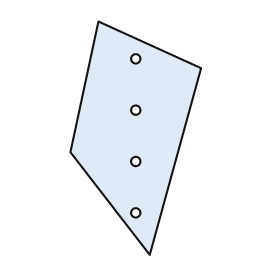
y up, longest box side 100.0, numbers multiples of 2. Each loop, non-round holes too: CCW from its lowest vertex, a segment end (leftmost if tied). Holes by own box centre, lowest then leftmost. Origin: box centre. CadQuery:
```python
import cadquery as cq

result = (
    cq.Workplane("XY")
    .moveTo(6.0, -50.0)
    .lineTo(28.0, 30.0)
    .lineTo(-16.0, 50.0)
    .lineTo(-28.0, -6.0)
    .close()
    .moveTo(0.0, -32.0)
    .circle(2.0)
    .moveTo(0.0, -10.0)
    .circle(2.0)
    .moveTo(0.0, 12.0)
    .circle(2.0)
    .moveTo(0.0, 34.0)
    .circle(2.0)
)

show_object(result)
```